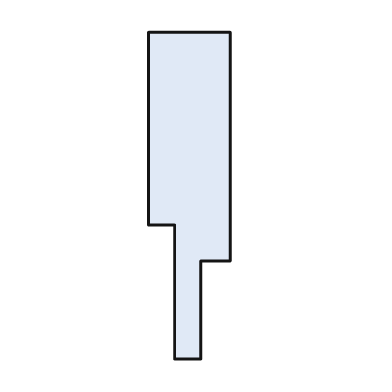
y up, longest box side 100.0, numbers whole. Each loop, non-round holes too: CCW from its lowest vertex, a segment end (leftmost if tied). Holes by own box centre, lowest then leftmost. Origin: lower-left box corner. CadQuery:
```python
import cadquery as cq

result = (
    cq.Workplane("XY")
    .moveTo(8.0, 0.0)
    .lineTo(16.0, 0.0)
    .lineTo(16.0, 30.0)
    .lineTo(25.0, 30.0)
    .lineTo(25.0, 100.0)
    .lineTo(0.0, 100.0)
    .lineTo(0.0, 41.0)
    .lineTo(8.0, 41.0)
    .close()
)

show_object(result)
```